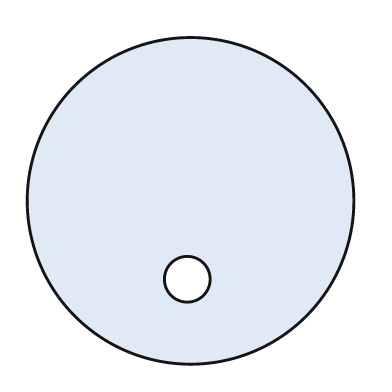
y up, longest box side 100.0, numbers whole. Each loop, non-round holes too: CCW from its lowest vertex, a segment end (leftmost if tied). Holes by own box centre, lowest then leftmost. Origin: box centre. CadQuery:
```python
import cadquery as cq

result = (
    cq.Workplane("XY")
    .moveTo(0.0, 0.0)
    .circle(50.0)
    .moveTo(-1.0, -24.0)
    .circle(7.0)
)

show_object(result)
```